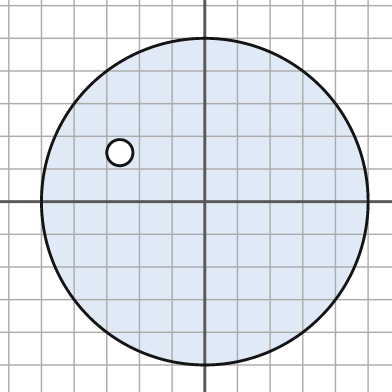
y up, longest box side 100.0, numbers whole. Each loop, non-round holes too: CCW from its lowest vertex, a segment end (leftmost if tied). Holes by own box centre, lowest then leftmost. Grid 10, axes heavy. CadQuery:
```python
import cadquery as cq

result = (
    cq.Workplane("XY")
    .moveTo(0.0, 0.0)
    .circle(50.0)
    .moveTo(-26.0, 15.0)
    .circle(4.0)
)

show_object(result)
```